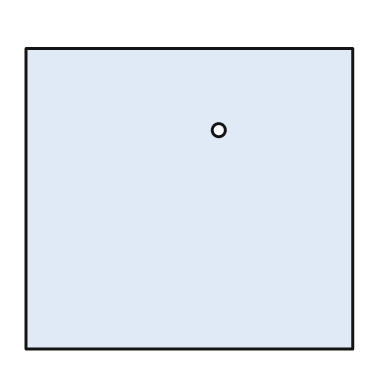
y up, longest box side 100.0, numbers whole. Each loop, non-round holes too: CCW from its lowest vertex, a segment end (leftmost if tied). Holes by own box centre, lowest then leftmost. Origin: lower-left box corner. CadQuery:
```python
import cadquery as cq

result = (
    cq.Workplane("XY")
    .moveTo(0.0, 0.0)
    .lineTo(100.0, 0.0)
    .lineTo(100.0, 92.0)
    .lineTo(0.0, 92.0)
    .close()
    .moveTo(59.0, 67.0)
    .circle(2.0)
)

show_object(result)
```